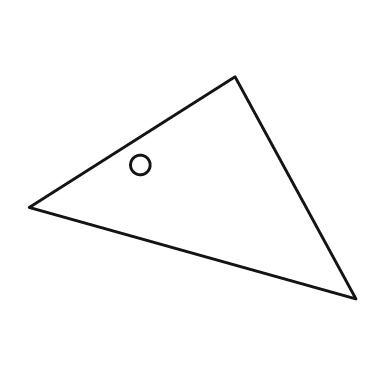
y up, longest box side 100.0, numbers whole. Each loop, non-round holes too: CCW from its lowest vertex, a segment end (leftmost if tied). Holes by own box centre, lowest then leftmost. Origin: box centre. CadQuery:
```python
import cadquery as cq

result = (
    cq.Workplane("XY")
    .moveTo(50.0, -34.0)
    .lineTo(13.0, 34.0)
    .lineTo(-50.0, -6.0)
    .close()
    .moveTo(-16.0, 7.0)
    .circle(3.0)
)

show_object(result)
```